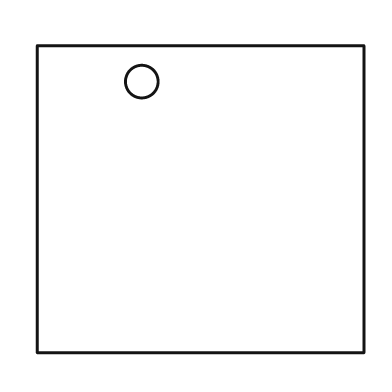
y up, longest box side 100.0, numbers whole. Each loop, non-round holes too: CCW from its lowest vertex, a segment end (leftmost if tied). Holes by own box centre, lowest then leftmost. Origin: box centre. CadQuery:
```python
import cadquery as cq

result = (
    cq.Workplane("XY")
    .moveTo(-50.0, -47.0)
    .lineTo(50.0, -47.0)
    .lineTo(50.0, 47.0)
    .lineTo(-50.0, 47.0)
    .close()
    .moveTo(-18.0, 36.0)
    .circle(5.0)
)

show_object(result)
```